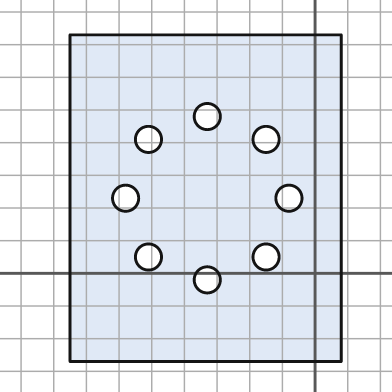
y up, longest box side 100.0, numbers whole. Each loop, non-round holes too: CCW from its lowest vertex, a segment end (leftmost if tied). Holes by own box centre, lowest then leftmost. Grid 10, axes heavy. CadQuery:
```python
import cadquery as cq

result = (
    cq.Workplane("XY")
    .moveTo(-75.0, -27.0)
    .lineTo(8.0, -27.0)
    .lineTo(8.0, 73.0)
    .lineTo(-75.0, 73.0)
    .close()
    .moveTo(-33.0, -2.0)
    .circle(4.0)
    .moveTo(-51.0, 5.0)
    .circle(4.0)
    .moveTo(-15.0, 5.0)
    .circle(4.0)
    .moveTo(-58.0, 23.0)
    .circle(4.0)
    .moveTo(-8.0, 23.0)
    .circle(4.0)
    .moveTo(-51.0, 41.0)
    .circle(4.0)
    .moveTo(-15.0, 41.0)
    .circle(4.0)
    .moveTo(-33.0, 48.0)
    .circle(4.0)
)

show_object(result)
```